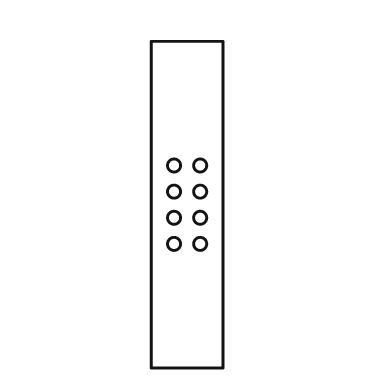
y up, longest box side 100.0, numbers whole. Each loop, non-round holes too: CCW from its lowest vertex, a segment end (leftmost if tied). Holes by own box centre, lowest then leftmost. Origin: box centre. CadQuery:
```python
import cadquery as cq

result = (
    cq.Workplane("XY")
    .moveTo(-11.0, -50.0)
    .lineTo(11.0, -50.0)
    .lineTo(11.0, 50.0)
    .lineTo(-11.0, 50.0)
    .close()
    .moveTo(-4.0, -12.0)
    .circle(2.0)
    .moveTo(4.0, -12.0)
    .circle(2.0)
    .moveTo(-4.0, -4.0)
    .circle(2.0)
    .moveTo(4.0, -4.0)
    .circle(2.0)
    .moveTo(-4.0, 4.0)
    .circle(2.0)
    .moveTo(4.0, 4.0)
    .circle(2.0)
    .moveTo(-4.0, 12.0)
    .circle(2.0)
    .moveTo(4.0, 12.0)
    .circle(2.0)
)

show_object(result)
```